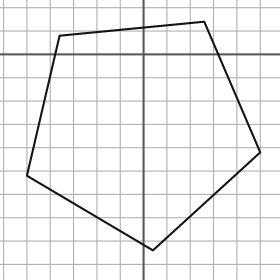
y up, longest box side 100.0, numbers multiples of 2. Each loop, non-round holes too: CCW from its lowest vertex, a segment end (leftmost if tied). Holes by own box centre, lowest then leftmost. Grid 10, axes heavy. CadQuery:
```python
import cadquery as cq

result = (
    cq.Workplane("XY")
    .moveTo(4.0, -84.0)
    .lineTo(50.0, -42.0)
    .lineTo(26.0, 14.0)
    .lineTo(-36.0, 8.0)
    .lineTo(-50.0, -52.0)
    .close()
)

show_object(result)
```